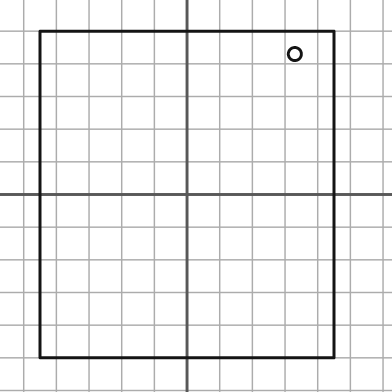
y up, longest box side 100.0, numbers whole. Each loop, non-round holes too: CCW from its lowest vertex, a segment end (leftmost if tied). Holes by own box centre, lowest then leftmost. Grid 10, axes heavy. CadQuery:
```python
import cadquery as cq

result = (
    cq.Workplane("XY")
    .moveTo(-45.0, -50.0)
    .lineTo(45.0, -50.0)
    .lineTo(45.0, 50.0)
    .lineTo(-45.0, 50.0)
    .close()
    .moveTo(33.0, 43.0)
    .circle(2.0)
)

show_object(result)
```